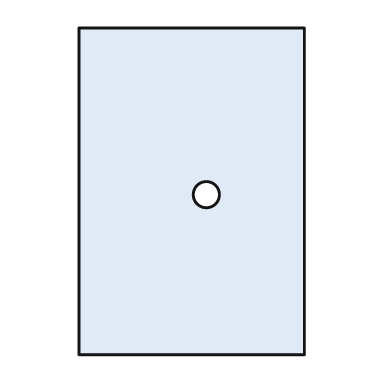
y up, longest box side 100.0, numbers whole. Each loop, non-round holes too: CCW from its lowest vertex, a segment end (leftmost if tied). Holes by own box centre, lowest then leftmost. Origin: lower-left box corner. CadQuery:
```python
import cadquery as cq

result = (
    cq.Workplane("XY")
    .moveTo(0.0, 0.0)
    .lineTo(69.0, 0.0)
    .lineTo(69.0, 100.0)
    .lineTo(0.0, 100.0)
    .close()
    .moveTo(39.0, 49.0)
    .circle(4.0)
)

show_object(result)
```